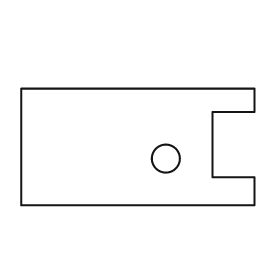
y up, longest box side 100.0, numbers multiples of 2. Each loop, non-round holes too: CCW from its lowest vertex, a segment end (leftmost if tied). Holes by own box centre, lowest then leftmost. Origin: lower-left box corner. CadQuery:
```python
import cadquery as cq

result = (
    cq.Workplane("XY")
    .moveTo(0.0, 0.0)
    .lineTo(100.0, 0.0)
    .lineTo(100.0, 12.0)
    .lineTo(82.0, 12.0)
    .lineTo(82.0, 40.0)
    .lineTo(100.0, 40.0)
    .lineTo(100.0, 50.0)
    .lineTo(0.0, 50.0)
    .close()
    .moveTo(62.0, 20.0)
    .circle(6.0)
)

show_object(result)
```